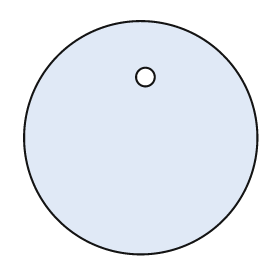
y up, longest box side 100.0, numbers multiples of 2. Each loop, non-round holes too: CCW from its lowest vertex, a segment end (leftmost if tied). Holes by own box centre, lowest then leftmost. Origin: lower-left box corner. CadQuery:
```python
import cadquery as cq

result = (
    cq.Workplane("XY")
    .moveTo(50.0, 50.0)
    .circle(50.0)
    .moveTo(52.0, 76.0)
    .circle(4.0)
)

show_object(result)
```